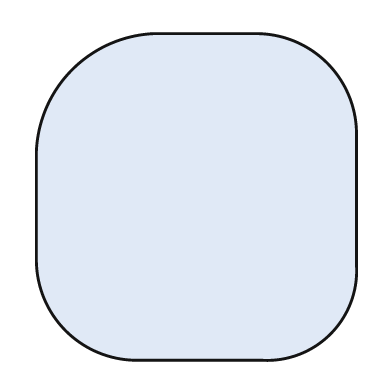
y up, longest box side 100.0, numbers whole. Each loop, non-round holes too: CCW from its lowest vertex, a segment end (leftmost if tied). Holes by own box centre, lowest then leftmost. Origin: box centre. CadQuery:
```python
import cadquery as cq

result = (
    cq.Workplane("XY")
    .moveTo(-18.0, -50.0)
    .lineTo(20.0, -50.0)
    .threePointArc((41.0, -42.0), (49.0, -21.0))
    .lineTo(49.0, 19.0)
    .threePointArc((40.0, 41.0), (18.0, 50.0))
    .lineTo(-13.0, 50.0)
    .threePointArc((-38.0, 39.0), (-49.0, 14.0))
    .lineTo(-49.0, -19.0)
    .threePointArc((-40.0, -41.0), (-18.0, -50.0))
    .close()
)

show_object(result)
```